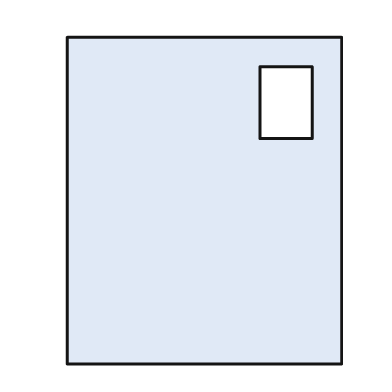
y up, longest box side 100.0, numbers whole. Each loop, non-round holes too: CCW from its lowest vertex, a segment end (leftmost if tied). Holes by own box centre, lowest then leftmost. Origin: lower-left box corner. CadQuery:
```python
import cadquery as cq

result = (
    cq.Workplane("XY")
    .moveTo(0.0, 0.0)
    .lineTo(84.0, 0.0)
    .lineTo(84.0, 100.0)
    .lineTo(0.0, 100.0)
    .close()
    .moveTo(59.0, 69.0)
    .lineTo(75.0, 69.0)
    .lineTo(75.0, 91.0)
    .lineTo(59.0, 91.0)
    .close()
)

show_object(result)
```